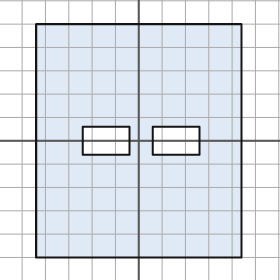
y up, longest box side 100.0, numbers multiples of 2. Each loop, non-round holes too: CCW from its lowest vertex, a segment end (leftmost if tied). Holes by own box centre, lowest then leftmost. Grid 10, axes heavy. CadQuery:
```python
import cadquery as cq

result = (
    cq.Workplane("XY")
    .moveTo(-44.0, -50.0)
    .lineTo(44.0, -50.0)
    .lineTo(44.0, 50.0)
    .lineTo(-44.0, 50.0)
    .close()
    .moveTo(-24.0, -6.0)
    .lineTo(-4.0, -6.0)
    .lineTo(-4.0, 6.0)
    .lineTo(-24.0, 6.0)
    .close()
    .moveTo(6.0, -6.0)
    .lineTo(26.0, -6.0)
    .lineTo(26.0, 6.0)
    .lineTo(6.0, 6.0)
    .close()
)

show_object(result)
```